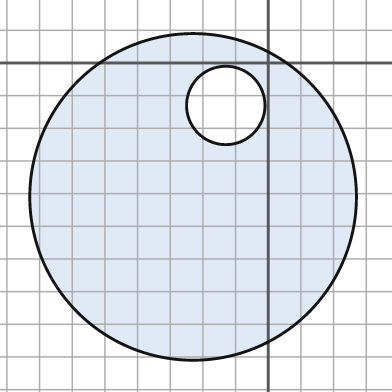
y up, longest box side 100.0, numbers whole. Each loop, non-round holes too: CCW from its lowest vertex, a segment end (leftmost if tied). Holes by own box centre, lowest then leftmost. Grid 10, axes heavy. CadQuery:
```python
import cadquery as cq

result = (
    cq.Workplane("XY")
    .moveTo(-23.0, -41.0)
    .circle(50.0)
    .moveTo(-13.0, -13.0)
    .circle(12.0)
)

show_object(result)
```